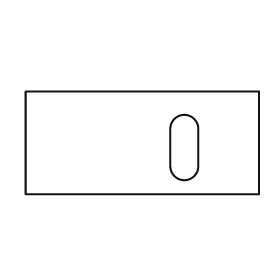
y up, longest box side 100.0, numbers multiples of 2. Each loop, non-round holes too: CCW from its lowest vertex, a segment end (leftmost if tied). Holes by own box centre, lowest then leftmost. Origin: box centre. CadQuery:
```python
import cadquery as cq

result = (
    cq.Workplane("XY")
    .moveTo(-50.0, -22.0)
    .lineTo(50.0, -22.0)
    .lineTo(50.0, 22.0)
    .lineTo(-50.0, 22.0)
    .close()
    .moveTo(12.0, -10.0)
    .threePointArc((18.0, -16.0), (24.0, -10.0))
    .lineTo(24.0, 6.0)
    .threePointArc((18.0, 12.0), (12.0, 6.0))
    .close()
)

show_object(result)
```